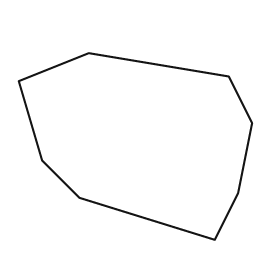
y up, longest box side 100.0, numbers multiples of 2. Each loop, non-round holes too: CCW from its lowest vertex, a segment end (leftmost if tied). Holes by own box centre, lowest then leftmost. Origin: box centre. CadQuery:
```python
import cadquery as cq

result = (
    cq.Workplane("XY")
    .moveTo(34.0, -40.0)
    .lineTo(44.0, -20.0)
    .lineTo(50.0, 10.0)
    .lineTo(40.0, 30.0)
    .lineTo(-20.0, 40.0)
    .lineTo(-50.0, 28.0)
    .lineTo(-40.0, -6.0)
    .lineTo(-24.0, -22.0)
    .close()
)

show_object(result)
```